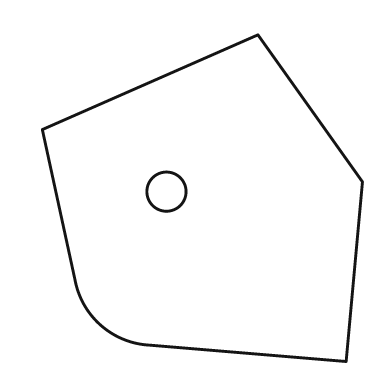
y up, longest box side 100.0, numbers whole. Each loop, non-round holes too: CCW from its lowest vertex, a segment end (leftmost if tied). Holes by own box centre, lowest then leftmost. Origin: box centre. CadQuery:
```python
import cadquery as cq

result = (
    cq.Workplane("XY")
    .moveTo(44.0, -50.0)
    .lineTo(49.0, 5.0)
    .lineTo(17.0, 50.0)
    .lineTo(-49.0, 21.0)
    .lineTo(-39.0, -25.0)
    .threePointArc((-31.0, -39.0), (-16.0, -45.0))
    .close()
    .moveTo(-11.0, 2.0)
    .circle(6.0)
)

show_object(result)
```